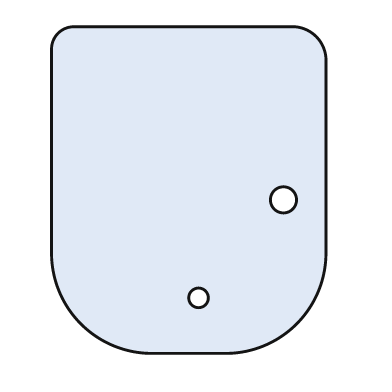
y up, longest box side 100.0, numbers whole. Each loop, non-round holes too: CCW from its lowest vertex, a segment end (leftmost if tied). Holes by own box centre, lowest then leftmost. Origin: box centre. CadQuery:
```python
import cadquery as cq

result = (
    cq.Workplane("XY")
    .moveTo(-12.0, -50.0)
    .lineTo(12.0, -50.0)
    .threePointArc((33.0, -41.0), (42.0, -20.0))
    .lineTo(42.0, 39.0)
    .threePointArc((39.0, 47.0), (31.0, 50.0))
    .lineTo(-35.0, 50.0)
    .threePointArc((-40.0, 48.0), (-42.0, 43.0))
    .lineTo(-42.0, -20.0)
    .threePointArc((-33.0, -41.0), (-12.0, -50.0))
    .close()
    .moveTo(3.0, -33.0)
    .circle(3.0)
    .moveTo(29.0, -3.0)
    .circle(4.0)
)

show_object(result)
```